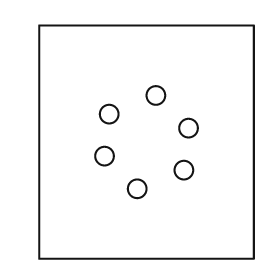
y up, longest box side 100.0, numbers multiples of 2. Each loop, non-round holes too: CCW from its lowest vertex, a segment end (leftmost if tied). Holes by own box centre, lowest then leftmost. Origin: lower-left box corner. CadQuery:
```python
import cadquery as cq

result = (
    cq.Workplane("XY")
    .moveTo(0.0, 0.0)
    .lineTo(92.0, 0.0)
    .lineTo(92.0, 100.0)
    .lineTo(0.0, 100.0)
    .close()
    .moveTo(42.0, 30.0)
    .circle(4.0)
    .moveTo(62.0, 38.0)
    .circle(4.0)
    .moveTo(28.0, 44.0)
    .circle(4.0)
    .moveTo(64.0, 56.0)
    .circle(4.0)
    .moveTo(30.0, 62.0)
    .circle(4.0)
    .moveTo(50.0, 70.0)
    .circle(4.0)
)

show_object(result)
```